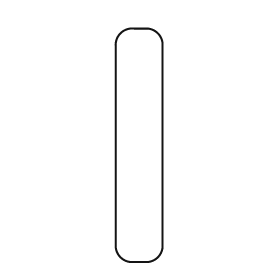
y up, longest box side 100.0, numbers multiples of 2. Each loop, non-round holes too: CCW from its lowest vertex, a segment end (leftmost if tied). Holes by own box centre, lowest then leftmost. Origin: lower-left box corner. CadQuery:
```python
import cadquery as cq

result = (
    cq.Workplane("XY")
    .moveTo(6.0, 0.0)
    .lineTo(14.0, 0.0)
    .threePointArc((18.0, 2.0), (20.0, 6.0))
    .lineTo(20.0, 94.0)
    .threePointArc((18.0, 98.0), (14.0, 100.0))
    .lineTo(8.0, 100.0)
    .threePointArc((2.0, 98.0), (0.0, 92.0))
    .lineTo(0.0, 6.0)
    .threePointArc((2.0, 2.0), (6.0, 0.0))
    .close()
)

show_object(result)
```